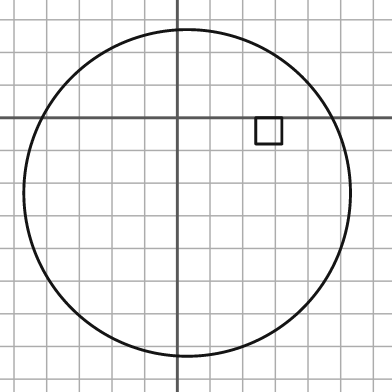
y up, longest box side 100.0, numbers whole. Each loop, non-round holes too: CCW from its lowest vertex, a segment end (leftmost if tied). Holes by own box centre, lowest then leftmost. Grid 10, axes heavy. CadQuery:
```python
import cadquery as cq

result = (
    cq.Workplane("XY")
    .moveTo(3.0, -23.0)
    .circle(50.0)
    .moveTo(24.0, -8.0)
    .lineTo(32.0, -8.0)
    .lineTo(32.0, 0.0)
    .lineTo(24.0, 0.0)
    .close()
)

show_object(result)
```